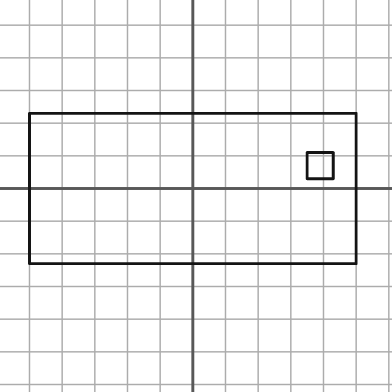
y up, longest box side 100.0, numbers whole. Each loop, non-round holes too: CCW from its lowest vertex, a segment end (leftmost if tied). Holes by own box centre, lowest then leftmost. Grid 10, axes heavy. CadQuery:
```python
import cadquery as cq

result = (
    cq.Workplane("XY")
    .moveTo(-50.0, -23.0)
    .lineTo(50.0, -23.0)
    .lineTo(50.0, 23.0)
    .lineTo(-50.0, 23.0)
    .close()
    .moveTo(35.0, 3.0)
    .lineTo(43.0, 3.0)
    .lineTo(43.0, 11.0)
    .lineTo(35.0, 11.0)
    .close()
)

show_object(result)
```